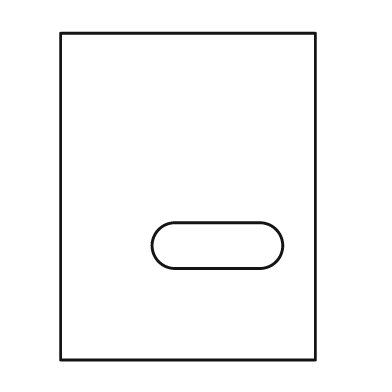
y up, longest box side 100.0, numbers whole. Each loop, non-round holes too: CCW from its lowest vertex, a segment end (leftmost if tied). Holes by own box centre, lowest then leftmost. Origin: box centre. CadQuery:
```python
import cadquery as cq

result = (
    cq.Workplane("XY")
    .moveTo(-39.0, -50.0)
    .lineTo(39.0, -50.0)
    .lineTo(39.0, 50.0)
    .lineTo(-39.0, 50.0)
    .close()
    .moveTo(-4.0, -22.0)
    .lineTo(22.0, -22.0)
    .threePointArc((29.0, -15.0), (22.0, -8.0))
    .lineTo(-4.0, -8.0)
    .threePointArc((-11.0, -15.0), (-4.0, -22.0))
    .close()
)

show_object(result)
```